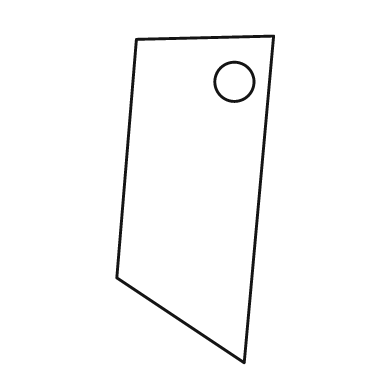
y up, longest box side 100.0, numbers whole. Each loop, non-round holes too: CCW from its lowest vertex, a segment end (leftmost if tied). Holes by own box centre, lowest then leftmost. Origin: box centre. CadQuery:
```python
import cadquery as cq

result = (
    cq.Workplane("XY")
    .moveTo(15.0, -50.0)
    .lineTo(24.0, 50.0)
    .lineTo(-18.0, 49.0)
    .lineTo(-24.0, -24.0)
    .close()
    .moveTo(12.0, 36.0)
    .circle(6.0)
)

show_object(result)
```